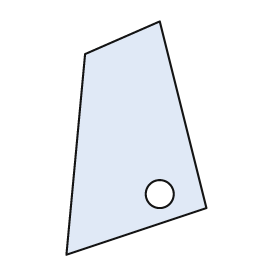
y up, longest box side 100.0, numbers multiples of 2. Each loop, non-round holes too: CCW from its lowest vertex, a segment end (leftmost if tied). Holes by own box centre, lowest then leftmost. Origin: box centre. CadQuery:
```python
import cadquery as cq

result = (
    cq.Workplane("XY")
    .moveTo(-30.0, -50.0)
    .lineTo(30.0, -30.0)
    .lineTo(10.0, 50.0)
    .lineTo(-22.0, 36.0)
    .close()
    .moveTo(10.0, -24.0)
    .circle(6.0)
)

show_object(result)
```